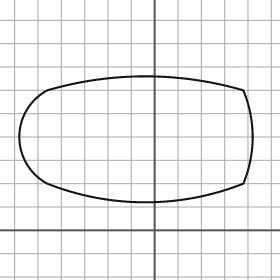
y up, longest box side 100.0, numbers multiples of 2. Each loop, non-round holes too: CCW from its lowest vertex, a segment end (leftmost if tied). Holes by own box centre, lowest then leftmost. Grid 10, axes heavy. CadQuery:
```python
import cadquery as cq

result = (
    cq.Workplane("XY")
    .moveTo(-46.0, 20.0)
    .threePointArc((-4.0, 12.0), (38.0, 20.0))
    .threePointArc((42.0, 40.0), (38.0, 60.0))
    .threePointArc((-4.0, 66.0), (-46.0, 60.0))
    .threePointArc((-58.0, 40.0), (-46.0, 20.0))
    .close()
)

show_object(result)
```